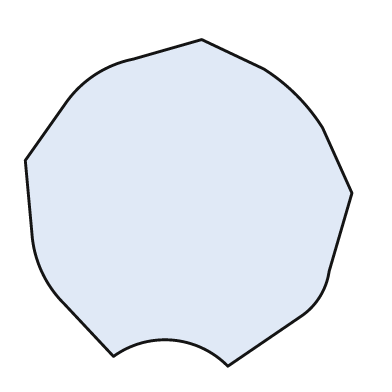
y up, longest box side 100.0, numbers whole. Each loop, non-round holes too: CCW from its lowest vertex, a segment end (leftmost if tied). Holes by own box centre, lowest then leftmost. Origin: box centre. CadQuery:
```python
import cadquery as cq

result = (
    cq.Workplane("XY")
    .moveTo(12.0, -50.0)
    .lineTo(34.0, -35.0)
    .threePointArc((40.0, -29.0), (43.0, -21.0))
    .lineTo(50.0, 3.0)
    .lineTo(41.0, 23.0)
    .threePointArc((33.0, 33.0), (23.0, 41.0))
    .lineTo(4.0, 50.0)
    .lineTo(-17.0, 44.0)
    .threePointArc((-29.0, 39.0), (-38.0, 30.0))
    .lineTo(-50.0, 13.0)
    .lineTo(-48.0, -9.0)
    .threePointArc((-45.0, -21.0), (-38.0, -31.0))
    .lineTo(-23.0, -47.0)
    .threePointArc((-5.0, -42.0), (12.0, -50.0))
    .close()
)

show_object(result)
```